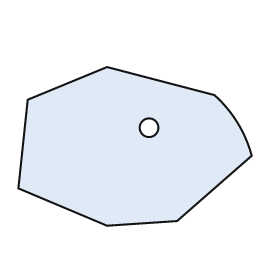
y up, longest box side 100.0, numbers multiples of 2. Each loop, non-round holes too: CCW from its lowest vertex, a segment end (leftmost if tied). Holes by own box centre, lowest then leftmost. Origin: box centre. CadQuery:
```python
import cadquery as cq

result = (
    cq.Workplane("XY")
    .moveTo(-12.0, -34.0)
    .lineTo(18.0, -32.0)
    .lineTo(50.0, -4.0)
    .threePointArc((44.0, 10.0), (34.0, 22.0))
    .lineTo(-12.0, 34.0)
    .lineTo(-46.0, 20.0)
    .lineTo(-50.0, -18.0)
    .close()
    .moveTo(6.0, 8.0)
    .circle(4.0)
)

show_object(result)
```